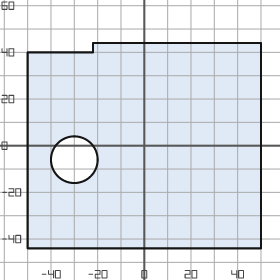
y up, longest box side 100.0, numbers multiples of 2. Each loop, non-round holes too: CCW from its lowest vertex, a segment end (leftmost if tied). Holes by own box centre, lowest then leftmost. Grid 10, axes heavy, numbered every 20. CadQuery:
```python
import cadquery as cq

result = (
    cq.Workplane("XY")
    .moveTo(-50.0, -44.0)
    .lineTo(50.0, -44.0)
    .lineTo(50.0, 44.0)
    .lineTo(-22.0, 44.0)
    .lineTo(-22.0, 40.0)
    .lineTo(-50.0, 40.0)
    .close()
    .moveTo(-30.0, -6.0)
    .circle(10.0)
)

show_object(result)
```